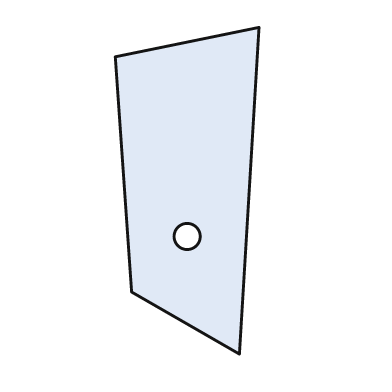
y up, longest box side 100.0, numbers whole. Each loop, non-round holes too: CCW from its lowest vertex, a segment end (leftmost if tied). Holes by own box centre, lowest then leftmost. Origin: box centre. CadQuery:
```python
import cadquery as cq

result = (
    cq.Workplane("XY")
    .moveTo(16.0, -50.0)
    .lineTo(22.0, 50.0)
    .lineTo(-22.0, 41.0)
    .lineTo(-17.0, -31.0)
    .close()
    .moveTo(0.0, -14.0)
    .circle(4.0)
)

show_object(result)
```